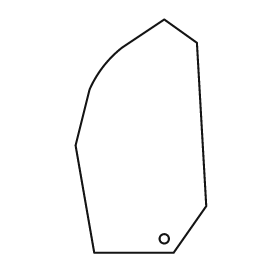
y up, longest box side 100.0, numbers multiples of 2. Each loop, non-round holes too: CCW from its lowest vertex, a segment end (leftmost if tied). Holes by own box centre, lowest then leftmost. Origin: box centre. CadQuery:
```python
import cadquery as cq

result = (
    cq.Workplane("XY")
    .moveTo(-20.0, -50.0)
    .lineTo(14.0, -50.0)
    .lineTo(28.0, -30.0)
    .lineTo(24.0, 40.0)
    .lineTo(10.0, 50.0)
    .lineTo(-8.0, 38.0)
    .threePointArc((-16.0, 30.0), (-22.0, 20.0))
    .lineTo(-28.0, -4.0)
    .close()
    .moveTo(10.0, -44.0)
    .circle(2.0)
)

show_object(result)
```